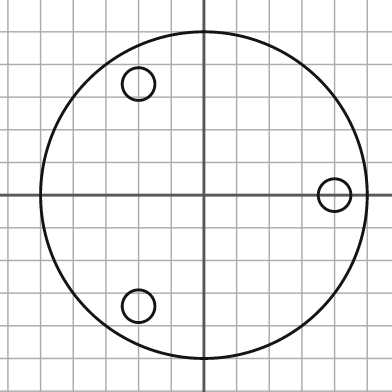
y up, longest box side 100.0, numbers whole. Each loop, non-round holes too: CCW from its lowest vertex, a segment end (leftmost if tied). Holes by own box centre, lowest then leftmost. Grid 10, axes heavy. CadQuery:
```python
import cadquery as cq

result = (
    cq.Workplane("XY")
    .moveTo(0.0, 0.0)
    .circle(50.0)
    .moveTo(-20.0, -34.0)
    .circle(5.0)
    .moveTo(40.0, 0.0)
    .circle(5.0)
    .moveTo(-20.0, 34.0)
    .circle(5.0)
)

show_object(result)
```